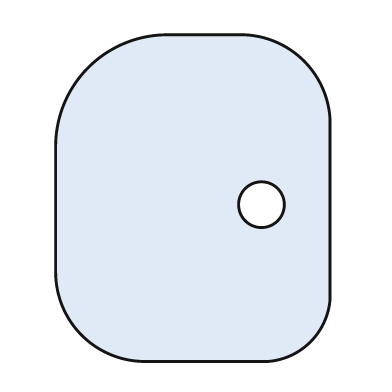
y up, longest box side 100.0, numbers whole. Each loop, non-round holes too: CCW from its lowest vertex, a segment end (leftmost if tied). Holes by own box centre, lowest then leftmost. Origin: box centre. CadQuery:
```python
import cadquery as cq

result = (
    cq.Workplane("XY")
    .moveTo(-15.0, -50.0)
    .lineTo(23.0, -50.0)
    .threePointArc((36.0, -44.0), (42.0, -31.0))
    .lineTo(42.0, 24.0)
    .threePointArc((34.0, 42.0), (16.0, 50.0))
    .lineTo(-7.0, 50.0)
    .threePointArc((-32.0, 40.0), (-42.0, 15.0))
    .lineTo(-42.0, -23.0)
    .threePointArc((-34.0, -42.0), (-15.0, -50.0))
    .close()
    .moveTo(21.0, -2.0)
    .circle(7.0)
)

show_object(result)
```